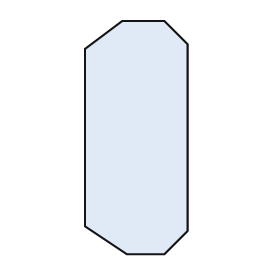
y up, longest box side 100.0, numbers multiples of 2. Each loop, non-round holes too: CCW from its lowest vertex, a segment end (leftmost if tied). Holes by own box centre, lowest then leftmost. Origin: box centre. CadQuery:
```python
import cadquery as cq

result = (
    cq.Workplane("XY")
    .moveTo(-4.0, -50.0)
    .lineTo(12.0, -50.0)
    .lineTo(22.0, -40.0)
    .lineTo(22.0, 40.0)
    .lineTo(12.0, 50.0)
    .lineTo(-6.0, 50.0)
    .lineTo(-22.0, 38.0)
    .lineTo(-22.0, -38.0)
    .close()
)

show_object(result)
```